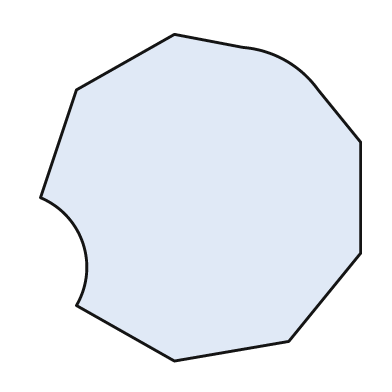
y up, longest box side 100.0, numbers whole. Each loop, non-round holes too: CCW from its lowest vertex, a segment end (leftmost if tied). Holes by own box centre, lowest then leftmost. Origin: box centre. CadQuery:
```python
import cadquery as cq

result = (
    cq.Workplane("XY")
    .moveTo(-8.0, -50.0)
    .lineTo(27.0, -44.0)
    .lineTo(49.0, -17.0)
    .lineTo(49.0, 17.0)
    .lineTo(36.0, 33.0)
    .threePointArc((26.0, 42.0), (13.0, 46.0))
    .lineTo(-8.0, 50.0)
    .lineTo(-38.0, 33.0)
    .lineTo(-49.0, 0.0)
    .threePointArc((-36.0, -14.0), (-38.0, -33.0))
    .close()
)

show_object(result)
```